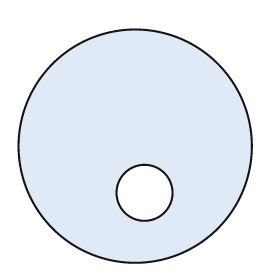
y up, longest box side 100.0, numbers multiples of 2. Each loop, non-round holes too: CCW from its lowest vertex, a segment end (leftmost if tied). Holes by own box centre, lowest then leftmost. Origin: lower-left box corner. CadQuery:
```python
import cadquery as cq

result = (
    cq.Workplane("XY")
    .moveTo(50.0, 50.0)
    .circle(50.0)
    .moveTo(54.0, 30.0)
    .circle(12.0)
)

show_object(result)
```